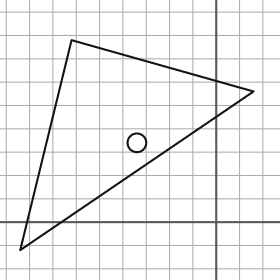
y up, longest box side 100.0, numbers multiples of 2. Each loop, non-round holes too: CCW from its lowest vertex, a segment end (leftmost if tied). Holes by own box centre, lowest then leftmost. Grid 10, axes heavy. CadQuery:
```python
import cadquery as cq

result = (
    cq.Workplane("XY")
    .moveTo(-84.0, -12.0)
    .lineTo(16.0, 56.0)
    .lineTo(-62.0, 78.0)
    .close()
    .moveTo(-34.0, 34.0)
    .circle(4.0)
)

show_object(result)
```